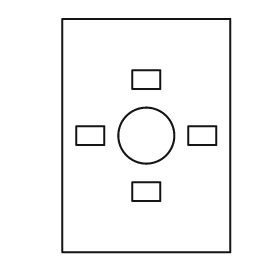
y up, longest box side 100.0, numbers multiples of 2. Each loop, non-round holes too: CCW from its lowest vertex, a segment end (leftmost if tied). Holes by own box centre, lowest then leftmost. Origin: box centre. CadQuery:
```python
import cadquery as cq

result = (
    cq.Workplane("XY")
    .moveTo(-36.0, -50.0)
    .lineTo(36.0, -50.0)
    .lineTo(36.0, 50.0)
    .lineTo(-36.0, 50.0)
    .close()
    .moveTo(-6.0, -28.0)
    .lineTo(6.0, -28.0)
    .lineTo(6.0, -20.0)
    .lineTo(-6.0, -20.0)
    .close()
    .moveTo(-30.0, -4.0)
    .lineTo(-18.0, -4.0)
    .lineTo(-18.0, 4.0)
    .lineTo(-30.0, 4.0)
    .close()
    .moveTo(0.0, 0.0)
    .circle(12.0)
    .moveTo(18.0, -4.0)
    .lineTo(30.0, -4.0)
    .lineTo(30.0, 4.0)
    .lineTo(18.0, 4.0)
    .close()
    .moveTo(-6.0, 20.0)
    .lineTo(6.0, 20.0)
    .lineTo(6.0, 28.0)
    .lineTo(-6.0, 28.0)
    .close()
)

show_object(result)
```